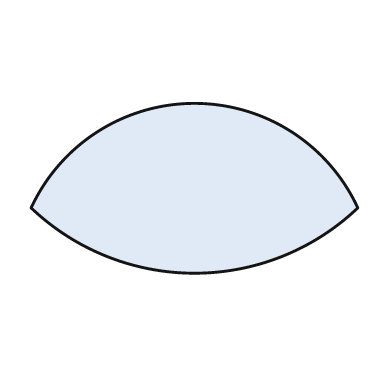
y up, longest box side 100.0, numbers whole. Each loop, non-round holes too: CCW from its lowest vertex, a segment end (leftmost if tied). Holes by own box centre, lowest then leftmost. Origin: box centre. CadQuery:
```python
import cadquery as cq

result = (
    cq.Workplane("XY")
    .moveTo(-50.0, -6.0)
    .threePointArc((0.0, -26.0), (50.0, -6.0))
    .threePointArc((0.0, 26.0), (-50.0, -6.0))
    .close()
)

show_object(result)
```